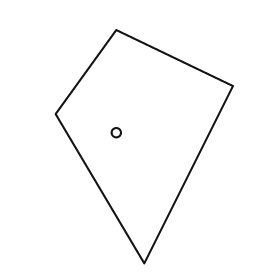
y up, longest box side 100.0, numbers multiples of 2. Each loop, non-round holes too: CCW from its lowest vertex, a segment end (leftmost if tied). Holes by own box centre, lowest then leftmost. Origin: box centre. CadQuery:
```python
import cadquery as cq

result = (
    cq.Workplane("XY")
    .moveTo(0.0, -50.0)
    .lineTo(38.0, 26.0)
    .lineTo(-12.0, 50.0)
    .lineTo(-38.0, 14.0)
    .close()
    .moveTo(-12.0, 6.0)
    .circle(2.0)
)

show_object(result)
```